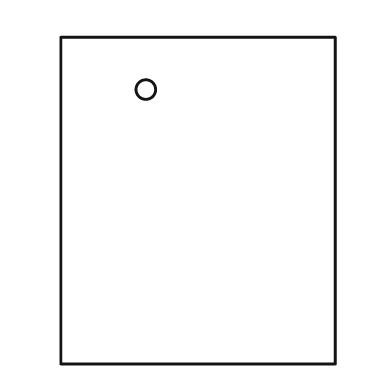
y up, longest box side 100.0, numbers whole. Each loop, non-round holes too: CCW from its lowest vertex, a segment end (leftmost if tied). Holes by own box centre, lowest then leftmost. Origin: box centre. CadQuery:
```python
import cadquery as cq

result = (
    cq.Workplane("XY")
    .moveTo(-42.0, -50.0)
    .lineTo(42.0, -50.0)
    .lineTo(42.0, 50.0)
    .lineTo(-42.0, 50.0)
    .close()
    .moveTo(-16.0, 34.0)
    .circle(3.0)
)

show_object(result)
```